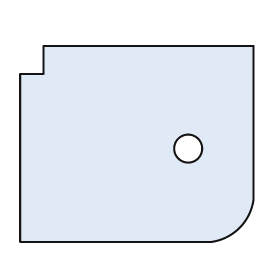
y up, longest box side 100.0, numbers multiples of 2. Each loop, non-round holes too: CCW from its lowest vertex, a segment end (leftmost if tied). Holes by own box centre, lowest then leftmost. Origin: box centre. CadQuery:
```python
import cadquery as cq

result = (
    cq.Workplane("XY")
    .moveTo(-50.0, -42.0)
    .lineTo(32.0, -42.0)
    .threePointArc((44.0, -36.0), (50.0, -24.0))
    .lineTo(50.0, 42.0)
    .lineTo(-40.0, 42.0)
    .lineTo(-40.0, 30.0)
    .lineTo(-50.0, 30.0)
    .close()
    .moveTo(22.0, -2.0)
    .circle(6.0)
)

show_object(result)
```